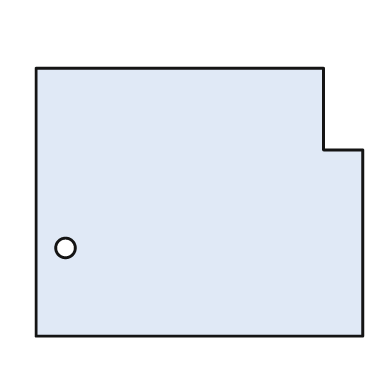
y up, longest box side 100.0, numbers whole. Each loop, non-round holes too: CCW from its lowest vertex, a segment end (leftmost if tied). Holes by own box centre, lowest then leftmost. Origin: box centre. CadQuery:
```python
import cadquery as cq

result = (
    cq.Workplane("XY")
    .moveTo(-50.0, -41.0)
    .lineTo(50.0, -41.0)
    .lineTo(50.0, 16.0)
    .lineTo(38.0, 16.0)
    .lineTo(38.0, 41.0)
    .lineTo(-50.0, 41.0)
    .close()
    .moveTo(-41.0, -14.0)
    .circle(3.0)
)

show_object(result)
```